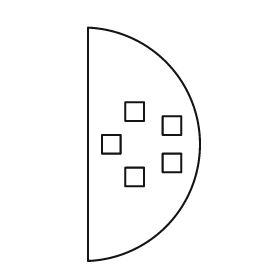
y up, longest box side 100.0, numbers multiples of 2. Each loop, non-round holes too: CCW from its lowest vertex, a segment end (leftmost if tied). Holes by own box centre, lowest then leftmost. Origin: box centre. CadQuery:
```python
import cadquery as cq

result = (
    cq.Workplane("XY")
    .moveTo(-24.0, -50.0)
    .threePointArc((24.0, 0.0), (-24.0, 50.0))
    .close()
    .moveTo(-8.0, -18.0)
    .lineTo(0.0, -18.0)
    .lineTo(0.0, -10.0)
    .lineTo(-8.0, -10.0)
    .close()
    .moveTo(8.0, -12.0)
    .lineTo(16.0, -12.0)
    .lineTo(16.0, -4.0)
    .lineTo(8.0, -4.0)
    .close()
    .moveTo(-18.0, -4.0)
    .lineTo(-10.0, -4.0)
    .lineTo(-10.0, 4.0)
    .lineTo(-18.0, 4.0)
    .close()
    .moveTo(8.0, 4.0)
    .lineTo(16.0, 4.0)
    .lineTo(16.0, 12.0)
    .lineTo(8.0, 12.0)
    .close()
    .moveTo(-8.0, 10.0)
    .lineTo(0.0, 10.0)
    .lineTo(0.0, 18.0)
    .lineTo(-8.0, 18.0)
    .close()
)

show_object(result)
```